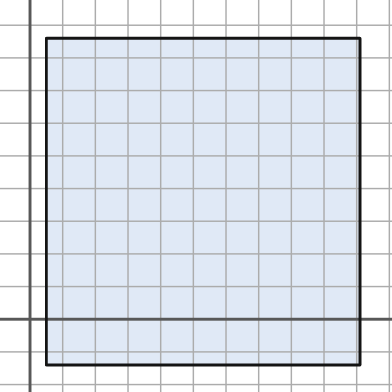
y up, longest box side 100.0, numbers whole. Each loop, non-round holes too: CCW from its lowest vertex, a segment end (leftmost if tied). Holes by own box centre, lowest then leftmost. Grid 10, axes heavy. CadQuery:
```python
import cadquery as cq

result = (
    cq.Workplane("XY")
    .moveTo(5.0, -14.0)
    .lineTo(101.0, -14.0)
    .lineTo(101.0, 86.0)
    .lineTo(5.0, 86.0)
    .close()
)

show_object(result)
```